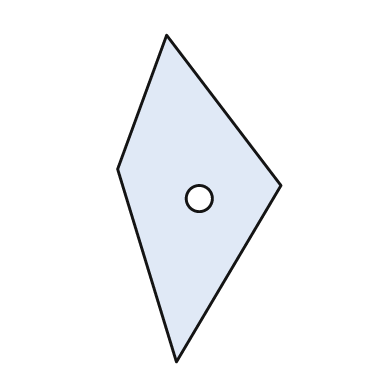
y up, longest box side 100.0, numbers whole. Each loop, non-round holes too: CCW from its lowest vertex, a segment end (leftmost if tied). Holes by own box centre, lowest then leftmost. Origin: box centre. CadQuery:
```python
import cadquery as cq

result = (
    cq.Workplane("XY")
    .moveTo(-7.0, -50.0)
    .lineTo(25.0, 4.0)
    .lineTo(-10.0, 50.0)
    .lineTo(-25.0, 9.0)
    .close()
    .moveTo(0.0, 0.0)
    .circle(4.0)
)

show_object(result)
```